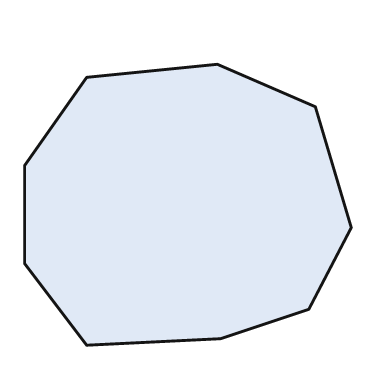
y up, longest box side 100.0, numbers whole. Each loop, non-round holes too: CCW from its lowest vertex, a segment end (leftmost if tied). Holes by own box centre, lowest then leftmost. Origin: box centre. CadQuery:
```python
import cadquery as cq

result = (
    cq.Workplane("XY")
    .moveTo(-31.0, -43.0)
    .lineTo(10.0, -41.0)
    .lineTo(37.0, -32.0)
    .lineTo(50.0, -7.0)
    .lineTo(39.0, 30.0)
    .lineTo(9.0, 43.0)
    .lineTo(-31.0, 39.0)
    .lineTo(-50.0, 12.0)
    .lineTo(-50.0, -18.0)
    .close()
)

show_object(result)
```